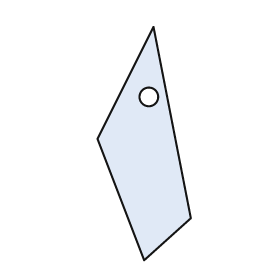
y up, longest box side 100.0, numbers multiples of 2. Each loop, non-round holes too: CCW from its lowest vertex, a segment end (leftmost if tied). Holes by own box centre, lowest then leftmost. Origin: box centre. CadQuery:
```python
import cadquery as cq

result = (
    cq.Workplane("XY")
    .moveTo(0.0, -50.0)
    .lineTo(20.0, -32.0)
    .lineTo(4.0, 50.0)
    .lineTo(-20.0, 2.0)
    .close()
    .moveTo(2.0, 20.0)
    .circle(4.0)
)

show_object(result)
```